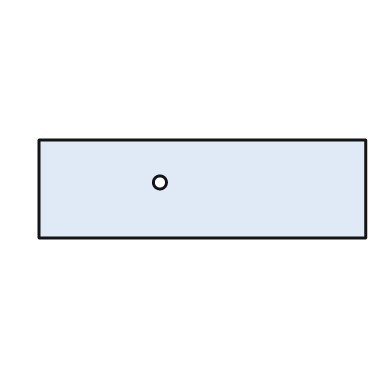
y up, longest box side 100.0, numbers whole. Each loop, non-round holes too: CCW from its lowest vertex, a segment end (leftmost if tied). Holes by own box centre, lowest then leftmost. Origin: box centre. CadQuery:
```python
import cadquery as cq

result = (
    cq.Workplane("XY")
    .moveTo(-50.0, -15.0)
    .lineTo(50.0, -15.0)
    .lineTo(50.0, 15.0)
    .lineTo(-50.0, 15.0)
    .close()
    .moveTo(-13.0, 2.0)
    .circle(2.0)
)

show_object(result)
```